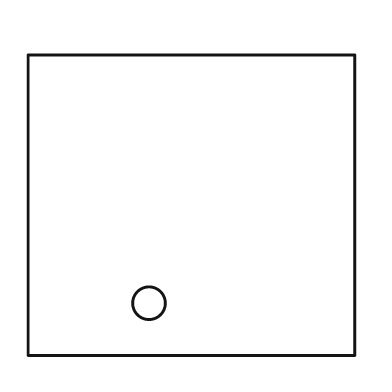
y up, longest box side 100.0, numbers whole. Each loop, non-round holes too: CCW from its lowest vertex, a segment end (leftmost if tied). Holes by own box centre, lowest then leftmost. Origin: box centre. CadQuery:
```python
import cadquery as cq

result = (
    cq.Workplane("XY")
    .moveTo(-50.0, -46.0)
    .lineTo(50.0, -46.0)
    .lineTo(50.0, 46.0)
    .lineTo(-50.0, 46.0)
    .close()
    .moveTo(-13.0, -30.0)
    .circle(5.0)
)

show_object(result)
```